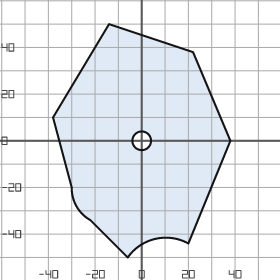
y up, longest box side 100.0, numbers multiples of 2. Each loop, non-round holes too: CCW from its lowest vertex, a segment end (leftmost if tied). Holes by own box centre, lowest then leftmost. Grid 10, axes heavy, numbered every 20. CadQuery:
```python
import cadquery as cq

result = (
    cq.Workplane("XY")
    .moveTo(-6.0, -50.0)
    .threePointArc((6.0, -42.0), (20.0, -44.0))
    .lineTo(38.0, 0.0)
    .lineTo(22.0, 38.0)
    .lineTo(-14.0, 50.0)
    .lineTo(-38.0, 10.0)
    .lineTo(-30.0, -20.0)
    .threePointArc((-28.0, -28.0), (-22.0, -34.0))
    .close()
    .moveTo(0.0, 0.0)
    .circle(4.0)
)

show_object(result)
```